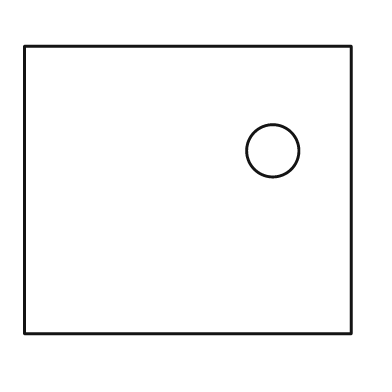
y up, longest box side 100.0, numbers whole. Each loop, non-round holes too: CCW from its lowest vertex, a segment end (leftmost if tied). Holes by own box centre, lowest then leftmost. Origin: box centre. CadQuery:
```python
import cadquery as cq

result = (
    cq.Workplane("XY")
    .moveTo(-50.0, -44.0)
    .lineTo(50.0, -44.0)
    .lineTo(50.0, 44.0)
    .lineTo(-50.0, 44.0)
    .close()
    .moveTo(26.0, 12.0)
    .circle(8.0)
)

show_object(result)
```